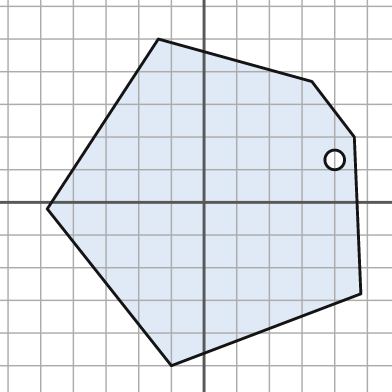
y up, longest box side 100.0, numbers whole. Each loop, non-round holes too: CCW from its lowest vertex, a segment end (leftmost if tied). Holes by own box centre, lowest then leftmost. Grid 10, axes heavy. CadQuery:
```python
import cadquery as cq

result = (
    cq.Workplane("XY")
    .moveTo(-10.0, -50.0)
    .lineTo(48.0, -28.0)
    .lineTo(46.0, 20.0)
    .lineTo(33.0, 37.0)
    .lineTo(-14.0, 50.0)
    .lineTo(-48.0, -2.0)
    .close()
    .moveTo(40.0, 13.0)
    .circle(3.0)
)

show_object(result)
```